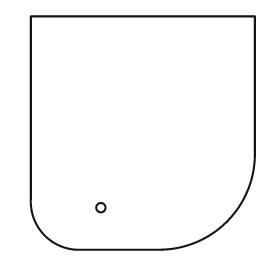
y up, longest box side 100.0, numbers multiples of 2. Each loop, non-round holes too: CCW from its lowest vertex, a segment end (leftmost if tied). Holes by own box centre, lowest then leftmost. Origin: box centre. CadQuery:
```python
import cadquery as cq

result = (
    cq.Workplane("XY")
    .moveTo(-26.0, -50.0)
    .lineTo(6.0, -50.0)
    .threePointArc((36.0, -38.0), (48.0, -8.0))
    .lineTo(48.0, 50.0)
    .lineTo(-48.0, 50.0)
    .lineTo(-48.0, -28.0)
    .threePointArc((-42.0, -44.0), (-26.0, -50.0))
    .close()
    .moveTo(-18.0, -32.0)
    .circle(2.0)
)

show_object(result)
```